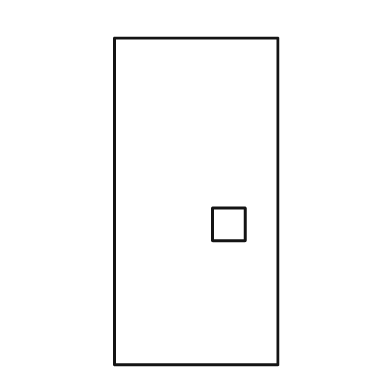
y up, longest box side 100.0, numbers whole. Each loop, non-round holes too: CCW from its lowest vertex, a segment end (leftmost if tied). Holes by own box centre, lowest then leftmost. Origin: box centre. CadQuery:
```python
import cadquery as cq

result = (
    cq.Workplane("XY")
    .moveTo(-25.0, -50.0)
    .lineTo(25.0, -50.0)
    .lineTo(25.0, 50.0)
    .lineTo(-25.0, 50.0)
    .close()
    .moveTo(5.0, -12.0)
    .lineTo(15.0, -12.0)
    .lineTo(15.0, -2.0)
    .lineTo(5.0, -2.0)
    .close()
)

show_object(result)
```